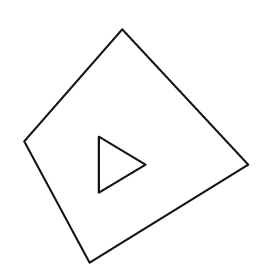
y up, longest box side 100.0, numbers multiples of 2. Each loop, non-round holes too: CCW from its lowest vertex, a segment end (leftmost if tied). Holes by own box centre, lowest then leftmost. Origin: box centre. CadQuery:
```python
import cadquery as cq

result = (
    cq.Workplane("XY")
    .moveTo(-20.0, -50.0)
    .lineTo(48.0, -8.0)
    .lineTo(-6.0, 50.0)
    .lineTo(-48.0, 2.0)
    .close()
    .moveTo(-16.0, -20.0)
    .lineTo(4.0, -8.0)
    .lineTo(-16.0, 4.0)
    .close()
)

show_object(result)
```